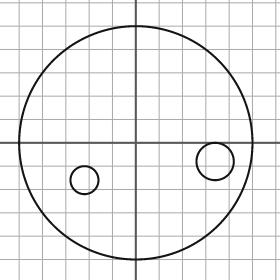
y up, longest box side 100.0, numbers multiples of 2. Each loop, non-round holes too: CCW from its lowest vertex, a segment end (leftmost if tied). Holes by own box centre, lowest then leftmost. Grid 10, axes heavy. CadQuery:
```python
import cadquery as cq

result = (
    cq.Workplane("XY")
    .moveTo(0.0, 0.0)
    .circle(50.0)
    .moveTo(-22.0, -16.0)
    .circle(6.0)
    .moveTo(34.0, -8.0)
    .circle(8.0)
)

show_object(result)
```